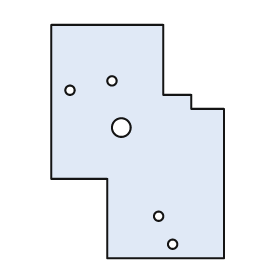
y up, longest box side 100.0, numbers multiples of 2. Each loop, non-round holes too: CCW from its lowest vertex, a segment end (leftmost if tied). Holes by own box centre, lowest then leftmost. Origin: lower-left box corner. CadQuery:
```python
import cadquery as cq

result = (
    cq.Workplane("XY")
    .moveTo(24.0, 0.0)
    .lineTo(74.0, 0.0)
    .lineTo(74.0, 64.0)
    .lineTo(60.0, 64.0)
    .lineTo(60.0, 70.0)
    .lineTo(48.0, 70.0)
    .lineTo(48.0, 100.0)
    .lineTo(0.0, 100.0)
    .lineTo(0.0, 34.0)
    .lineTo(24.0, 34.0)
    .close()
    .moveTo(52.0, 6.0)
    .circle(2.0)
    .moveTo(46.0, 18.0)
    .circle(2.0)
    .moveTo(30.0, 56.0)
    .circle(4.0)
    .moveTo(8.0, 72.0)
    .circle(2.0)
    .moveTo(26.0, 76.0)
    .circle(2.0)
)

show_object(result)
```